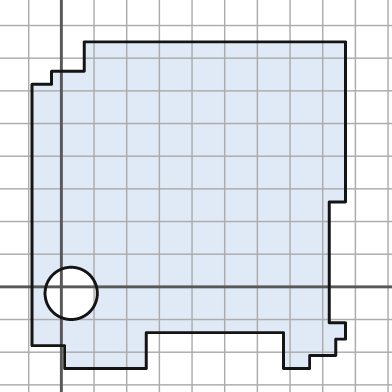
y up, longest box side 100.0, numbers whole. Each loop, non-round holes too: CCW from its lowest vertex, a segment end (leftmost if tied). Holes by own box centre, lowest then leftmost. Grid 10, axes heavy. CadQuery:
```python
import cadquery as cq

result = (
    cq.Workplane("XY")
    .moveTo(1.0, -25.0)
    .lineTo(26.0, -25.0)
    .lineTo(26.0, -14.0)
    .lineTo(68.0, -14.0)
    .lineTo(68.0, -25.0)
    .lineTo(76.0, -25.0)
    .lineTo(76.0, -21.0)
    .lineTo(84.0, -21.0)
    .lineTo(84.0, -16.0)
    .lineTo(87.0, -16.0)
    .lineTo(87.0, -11.0)
    .lineTo(82.0, -11.0)
    .lineTo(82.0, 26.0)
    .lineTo(87.0, 26.0)
    .lineTo(87.0, 75.0)
    .lineTo(7.0, 75.0)
    .lineTo(7.0, 66.0)
    .lineTo(-3.0, 66.0)
    .lineTo(-3.0, 62.0)
    .lineTo(-9.0, 62.0)
    .lineTo(-9.0, -18.0)
    .lineTo(1.0, -18.0)
    .close()
    .moveTo(3.0, -2.0)
    .circle(8.0)
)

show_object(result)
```